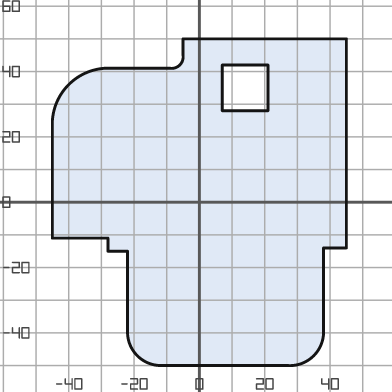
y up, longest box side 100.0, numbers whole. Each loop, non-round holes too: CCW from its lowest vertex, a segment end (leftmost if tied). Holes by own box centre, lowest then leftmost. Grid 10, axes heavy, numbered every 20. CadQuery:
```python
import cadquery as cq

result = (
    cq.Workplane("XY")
    .moveTo(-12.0, -50.0)
    .lineTo(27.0, -50.0)
    .threePointArc((35.0, -47.0), (38.0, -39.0))
    .lineTo(38.0, -14.0)
    .lineTo(45.0, -14.0)
    .lineTo(45.0, 50.0)
    .lineTo(-5.0, 50.0)
    .lineTo(-5.0, 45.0)
    .threePointArc((-6.0, 42.0), (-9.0, 41.0))
    .lineTo(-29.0, 41.0)
    .threePointArc((-40.0, 36.0), (-45.0, 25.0))
    .lineTo(-45.0, -11.0)
    .lineTo(-28.0, -11.0)
    .lineTo(-28.0, -15.0)
    .lineTo(-22.0, -15.0)
    .lineTo(-22.0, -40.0)
    .threePointArc((-19.0, -47.0), (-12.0, -50.0))
    .close()
    .moveTo(7.0, 28.0)
    .lineTo(21.0, 28.0)
    .lineTo(21.0, 42.0)
    .lineTo(7.0, 42.0)
    .close()
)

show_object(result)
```